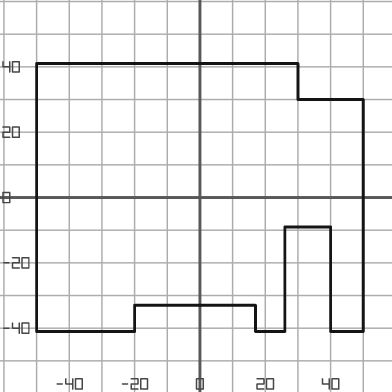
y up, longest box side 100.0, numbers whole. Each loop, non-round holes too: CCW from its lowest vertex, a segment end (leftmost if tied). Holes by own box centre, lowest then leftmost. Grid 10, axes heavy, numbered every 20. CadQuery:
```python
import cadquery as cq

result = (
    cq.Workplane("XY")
    .moveTo(-50.0, -41.0)
    .lineTo(-20.0, -41.0)
    .lineTo(-20.0, -33.0)
    .lineTo(17.0, -33.0)
    .lineTo(17.0, -41.0)
    .lineTo(26.0, -41.0)
    .lineTo(26.0, -9.0)
    .lineTo(40.0, -9.0)
    .lineTo(40.0, -41.0)
    .lineTo(50.0, -41.0)
    .lineTo(50.0, 30.0)
    .lineTo(30.0, 30.0)
    .lineTo(30.0, 41.0)
    .lineTo(-50.0, 41.0)
    .close()
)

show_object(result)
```